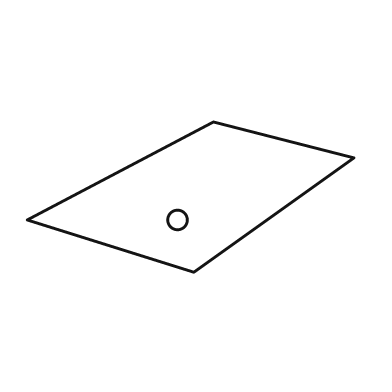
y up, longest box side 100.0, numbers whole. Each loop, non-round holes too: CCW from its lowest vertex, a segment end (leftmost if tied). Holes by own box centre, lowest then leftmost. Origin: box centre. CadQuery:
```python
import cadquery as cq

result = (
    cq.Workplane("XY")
    .moveTo(1.0, -23.0)
    .lineTo(50.0, 12.0)
    .lineTo(7.0, 23.0)
    .lineTo(-50.0, -7.0)
    .close()
    .moveTo(-4.0, -7.0)
    .circle(3.0)
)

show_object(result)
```